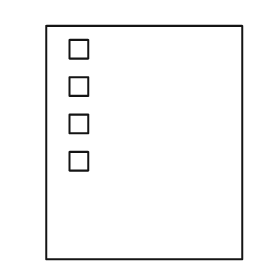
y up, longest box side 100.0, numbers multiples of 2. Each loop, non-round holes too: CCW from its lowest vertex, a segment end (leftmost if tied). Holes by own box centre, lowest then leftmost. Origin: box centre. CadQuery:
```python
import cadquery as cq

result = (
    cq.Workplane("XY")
    .moveTo(-42.0, -50.0)
    .lineTo(42.0, -50.0)
    .lineTo(42.0, 50.0)
    .lineTo(-42.0, 50.0)
    .close()
    .moveTo(-32.0, -12.0)
    .lineTo(-24.0, -12.0)
    .lineTo(-24.0, -4.0)
    .lineTo(-32.0, -4.0)
    .close()
    .moveTo(-32.0, 4.0)
    .lineTo(-24.0, 4.0)
    .lineTo(-24.0, 12.0)
    .lineTo(-32.0, 12.0)
    .close()
    .moveTo(-32.0, 20.0)
    .lineTo(-24.0, 20.0)
    .lineTo(-24.0, 28.0)
    .lineTo(-32.0, 28.0)
    .close()
    .moveTo(-32.0, 36.0)
    .lineTo(-24.0, 36.0)
    .lineTo(-24.0, 44.0)
    .lineTo(-32.0, 44.0)
    .close()
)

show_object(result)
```